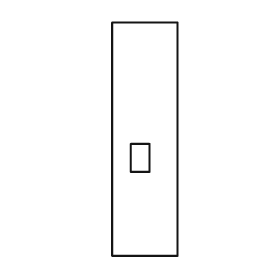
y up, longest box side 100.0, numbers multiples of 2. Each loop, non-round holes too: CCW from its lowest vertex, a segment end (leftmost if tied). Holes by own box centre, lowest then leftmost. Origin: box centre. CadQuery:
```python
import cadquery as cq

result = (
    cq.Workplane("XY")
    .moveTo(-14.0, -50.0)
    .lineTo(14.0, -50.0)
    .lineTo(14.0, 50.0)
    .lineTo(-14.0, 50.0)
    .close()
    .moveTo(-6.0, -14.0)
    .lineTo(2.0, -14.0)
    .lineTo(2.0, -2.0)
    .lineTo(-6.0, -2.0)
    .close()
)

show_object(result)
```